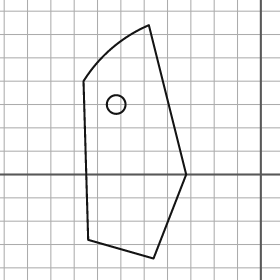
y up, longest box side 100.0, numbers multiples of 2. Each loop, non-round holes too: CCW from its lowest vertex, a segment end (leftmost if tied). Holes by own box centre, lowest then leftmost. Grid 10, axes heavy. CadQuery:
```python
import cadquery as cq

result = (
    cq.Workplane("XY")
    .moveTo(-46.0, -36.0)
    .lineTo(-32.0, 0.0)
    .lineTo(-48.0, 64.0)
    .threePointArc((-64.0, 54.0), (-76.0, 40.0))
    .lineTo(-74.0, -28.0)
    .close()
    .moveTo(-62.0, 30.0)
    .circle(4.0)
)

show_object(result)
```